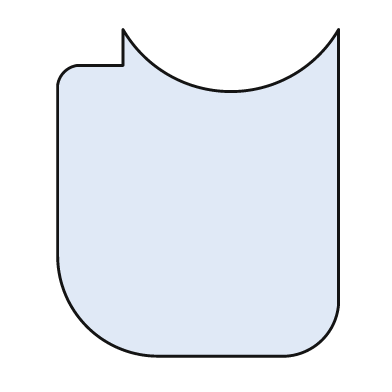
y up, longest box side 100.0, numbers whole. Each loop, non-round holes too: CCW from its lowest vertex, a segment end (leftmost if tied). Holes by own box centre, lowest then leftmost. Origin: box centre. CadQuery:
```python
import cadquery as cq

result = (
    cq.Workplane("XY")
    .moveTo(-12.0, -50.0)
    .lineTo(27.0, -50.0)
    .threePointArc((38.0, -45.0), (43.0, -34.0))
    .lineTo(43.0, 50.0)
    .threePointArc((10.0, 31.0), (-23.0, 50.0))
    .lineTo(-23.0, 39.0)
    .lineTo(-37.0, 39.0)
    .threePointArc((-41.0, 37.0), (-43.0, 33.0))
    .lineTo(-43.0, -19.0)
    .threePointArc((-34.0, -41.0), (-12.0, -50.0))
    .close()
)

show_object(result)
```